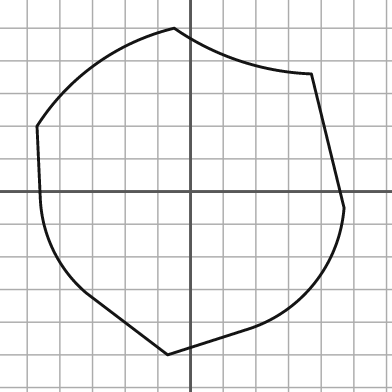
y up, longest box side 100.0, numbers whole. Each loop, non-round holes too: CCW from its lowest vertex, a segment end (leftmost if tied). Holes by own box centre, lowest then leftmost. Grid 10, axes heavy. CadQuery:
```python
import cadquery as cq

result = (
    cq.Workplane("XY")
    .moveTo(-7.0, -50.0)
    .lineTo(18.0, -42.0)
    .threePointArc((38.0, -28.0), (47.0, -5.0))
    .lineTo(37.0, 36.0)
    .threePointArc((15.0, 40.0), (-5.0, 50.0))
    .threePointArc((-29.0, 39.0), (-47.0, 20.0))
    .lineTo(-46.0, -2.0)
    .threePointArc((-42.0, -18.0), (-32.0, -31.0))
    .close()
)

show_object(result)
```